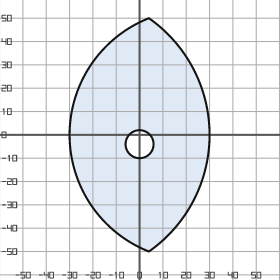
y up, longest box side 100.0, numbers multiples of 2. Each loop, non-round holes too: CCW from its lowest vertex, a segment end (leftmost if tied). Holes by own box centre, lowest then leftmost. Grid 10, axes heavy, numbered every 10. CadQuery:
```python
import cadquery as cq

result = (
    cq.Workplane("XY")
    .moveTo(4.0, -50.0)
    .threePointArc((30.0, 0.0), (4.0, 50.0))
    .threePointArc((-30.0, 0.0), (4.0, -50.0))
    .close()
    .moveTo(0.0, -4.0)
    .circle(6.0)
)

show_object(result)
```